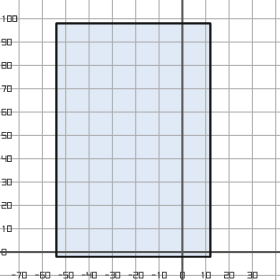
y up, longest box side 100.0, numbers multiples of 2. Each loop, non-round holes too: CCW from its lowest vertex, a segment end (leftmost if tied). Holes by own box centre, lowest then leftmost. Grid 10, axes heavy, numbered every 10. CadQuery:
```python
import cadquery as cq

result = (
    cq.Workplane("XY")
    .moveTo(-54.0, -2.0)
    .lineTo(12.0, -2.0)
    .lineTo(12.0, 98.0)
    .lineTo(-54.0, 98.0)
    .close()
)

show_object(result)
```